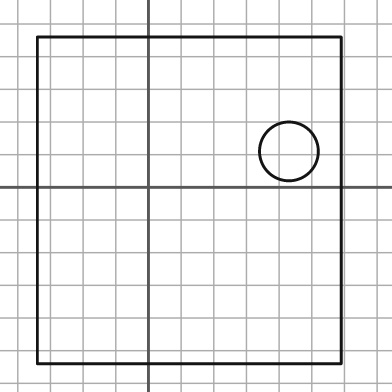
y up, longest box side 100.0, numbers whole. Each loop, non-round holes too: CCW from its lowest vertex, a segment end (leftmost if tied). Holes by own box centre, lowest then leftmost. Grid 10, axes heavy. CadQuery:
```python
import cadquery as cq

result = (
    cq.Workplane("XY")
    .moveTo(-34.0, -54.0)
    .lineTo(59.0, -54.0)
    .lineTo(59.0, 46.0)
    .lineTo(-34.0, 46.0)
    .close()
    .moveTo(43.0, 11.0)
    .circle(9.0)
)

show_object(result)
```